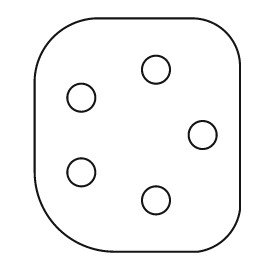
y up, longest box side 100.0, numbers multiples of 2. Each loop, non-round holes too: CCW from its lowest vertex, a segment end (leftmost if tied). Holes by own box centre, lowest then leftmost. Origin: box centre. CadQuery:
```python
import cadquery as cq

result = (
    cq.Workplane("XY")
    .moveTo(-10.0, -50.0)
    .lineTo(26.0, -50.0)
    .threePointArc((38.0, -44.0), (44.0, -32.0))
    .lineTo(44.0, 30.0)
    .threePointArc((38.0, 44.0), (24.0, 50.0))
    .lineTo(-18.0, 50.0)
    .threePointArc((-36.0, 42.0), (-44.0, 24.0))
    .lineTo(-44.0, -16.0)
    .threePointArc((-34.0, -40.0), (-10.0, -50.0))
    .close()
    .moveTo(8.0, -28.0)
    .circle(6.0)
    .moveTo(-24.0, -16.0)
    .circle(6.0)
    .moveTo(28.0, 0.0)
    .circle(6.0)
    .moveTo(-24.0, 16.0)
    .circle(6.0)
    .moveTo(8.0, 28.0)
    .circle(6.0)
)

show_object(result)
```